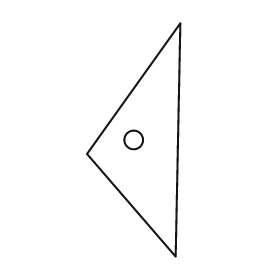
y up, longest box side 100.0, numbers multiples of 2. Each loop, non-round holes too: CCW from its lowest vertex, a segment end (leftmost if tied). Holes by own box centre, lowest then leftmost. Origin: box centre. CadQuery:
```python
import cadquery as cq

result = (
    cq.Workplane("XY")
    .moveTo(18.0, -50.0)
    .lineTo(20.0, 50.0)
    .lineTo(-20.0, -6.0)
    .close()
    .moveTo(0.0, 0.0)
    .circle(4.0)
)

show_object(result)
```